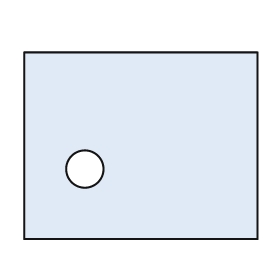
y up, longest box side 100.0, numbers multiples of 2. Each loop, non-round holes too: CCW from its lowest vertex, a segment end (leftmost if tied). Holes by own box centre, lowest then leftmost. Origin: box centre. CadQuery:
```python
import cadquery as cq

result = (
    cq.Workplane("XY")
    .moveTo(-50.0, -40.0)
    .lineTo(50.0, -40.0)
    .lineTo(50.0, 40.0)
    .lineTo(-50.0, 40.0)
    .close()
    .moveTo(-24.0, -10.0)
    .circle(8.0)
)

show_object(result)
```